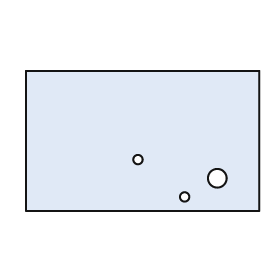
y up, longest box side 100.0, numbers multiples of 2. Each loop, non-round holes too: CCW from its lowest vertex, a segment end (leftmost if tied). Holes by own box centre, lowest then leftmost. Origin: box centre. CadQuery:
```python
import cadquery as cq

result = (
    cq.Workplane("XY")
    .moveTo(-50.0, -30.0)
    .lineTo(50.0, -30.0)
    .lineTo(50.0, 30.0)
    .lineTo(-50.0, 30.0)
    .close()
    .moveTo(18.0, -24.0)
    .circle(2.0)
    .moveTo(32.0, -16.0)
    .circle(4.0)
    .moveTo(-2.0, -8.0)
    .circle(2.0)
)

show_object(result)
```